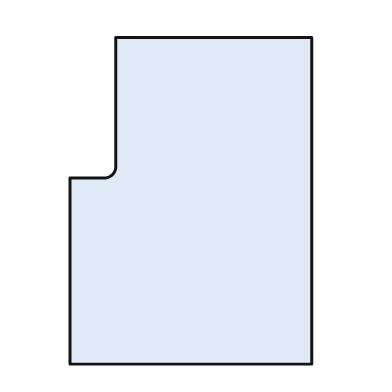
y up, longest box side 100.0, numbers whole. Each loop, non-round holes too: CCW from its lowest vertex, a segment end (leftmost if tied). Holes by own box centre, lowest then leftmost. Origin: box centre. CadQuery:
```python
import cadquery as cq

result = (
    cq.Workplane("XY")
    .moveTo(-37.0, -50.0)
    .lineTo(37.0, -50.0)
    .lineTo(37.0, 50.0)
    .lineTo(-23.0, 50.0)
    .lineTo(-23.0, 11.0)
    .threePointArc((-24.0, 8.0), (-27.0, 7.0))
    .lineTo(-37.0, 7.0)
    .close()
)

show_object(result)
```